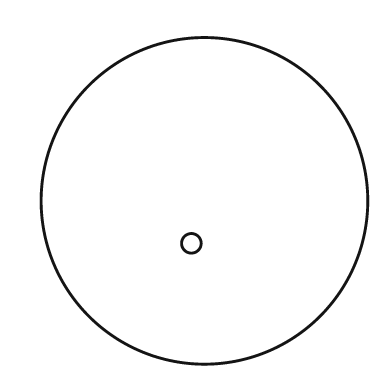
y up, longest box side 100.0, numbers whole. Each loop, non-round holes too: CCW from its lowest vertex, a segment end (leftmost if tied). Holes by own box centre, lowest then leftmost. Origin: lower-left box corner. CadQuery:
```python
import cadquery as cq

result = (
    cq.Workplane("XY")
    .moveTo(50.0, 50.0)
    .circle(50.0)
    .moveTo(46.0, 37.0)
    .circle(3.0)
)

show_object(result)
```